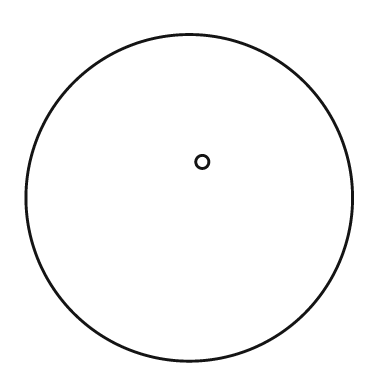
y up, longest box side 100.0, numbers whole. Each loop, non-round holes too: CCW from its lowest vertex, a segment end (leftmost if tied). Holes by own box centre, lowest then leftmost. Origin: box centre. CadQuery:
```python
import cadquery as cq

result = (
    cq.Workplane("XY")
    .moveTo(0.0, 0.0)
    .circle(50.0)
    .moveTo(4.0, 11.0)
    .circle(2.0)
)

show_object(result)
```